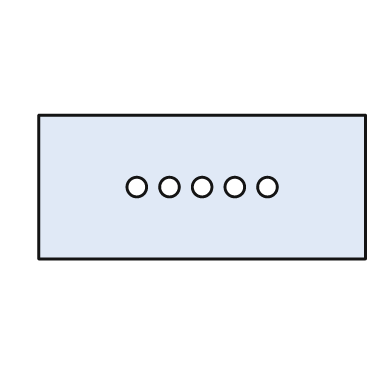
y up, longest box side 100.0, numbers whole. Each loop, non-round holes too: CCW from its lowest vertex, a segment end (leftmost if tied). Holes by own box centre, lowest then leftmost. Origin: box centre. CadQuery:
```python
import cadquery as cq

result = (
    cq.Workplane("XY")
    .moveTo(-50.0, -22.0)
    .lineTo(50.0, -22.0)
    .lineTo(50.0, 22.0)
    .lineTo(-50.0, 22.0)
    .close()
    .moveTo(-20.0, 0.0)
    .circle(3.0)
    .moveTo(-10.0, 0.0)
    .circle(3.0)
    .moveTo(0.0, 0.0)
    .circle(3.0)
    .moveTo(10.0, 0.0)
    .circle(3.0)
    .moveTo(20.0, 0.0)
    .circle(3.0)
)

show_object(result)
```